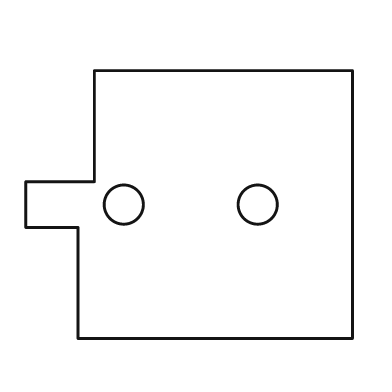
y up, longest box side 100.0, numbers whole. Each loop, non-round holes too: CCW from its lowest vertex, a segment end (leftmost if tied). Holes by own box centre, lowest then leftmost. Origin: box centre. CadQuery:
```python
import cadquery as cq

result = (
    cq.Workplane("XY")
    .moveTo(-34.0, -41.0)
    .lineTo(50.0, -41.0)
    .lineTo(50.0, 41.0)
    .lineTo(-29.0, 41.0)
    .lineTo(-29.0, 7.0)
    .lineTo(-50.0, 7.0)
    .lineTo(-50.0, -7.0)
    .lineTo(-34.0, -7.0)
    .close()
    .moveTo(-20.0, 0.0)
    .circle(6.0)
    .moveTo(21.0, 0.0)
    .circle(6.0)
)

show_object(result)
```